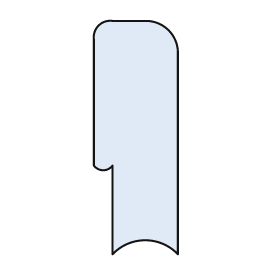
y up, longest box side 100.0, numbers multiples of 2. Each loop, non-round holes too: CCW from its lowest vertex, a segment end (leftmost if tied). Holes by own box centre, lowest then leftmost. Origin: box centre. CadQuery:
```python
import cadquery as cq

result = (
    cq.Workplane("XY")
    .moveTo(-10.0, -50.0)
    .threePointArc((4.0, -44.0), (18.0, -50.0))
    .lineTo(18.0, 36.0)
    .threePointArc((14.0, 46.0), (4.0, 50.0))
    .lineTo(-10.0, 50.0)
    .threePointArc((-16.0, 48.0), (-18.0, 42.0))
    .lineTo(-18.0, -12.0)
    .threePointArc((-14.0, -14.0), (-10.0, -12.0))
    .close()
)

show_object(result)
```